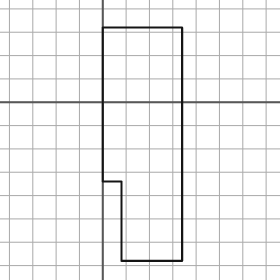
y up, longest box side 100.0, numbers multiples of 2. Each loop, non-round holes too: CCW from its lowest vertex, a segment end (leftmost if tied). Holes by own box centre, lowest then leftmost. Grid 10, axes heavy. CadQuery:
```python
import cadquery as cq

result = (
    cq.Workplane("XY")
    .moveTo(8.0, -68.0)
    .lineTo(34.0, -68.0)
    .lineTo(34.0, 32.0)
    .lineTo(0.0, 32.0)
    .lineTo(0.0, -34.0)
    .lineTo(8.0, -34.0)
    .close()
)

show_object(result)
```